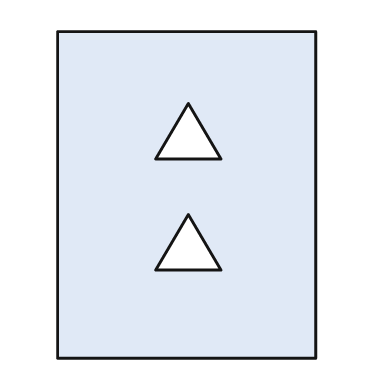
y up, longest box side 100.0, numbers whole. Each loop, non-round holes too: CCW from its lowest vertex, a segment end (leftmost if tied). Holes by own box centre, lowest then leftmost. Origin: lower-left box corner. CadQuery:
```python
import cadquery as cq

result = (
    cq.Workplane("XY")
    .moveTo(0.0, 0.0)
    .lineTo(79.0, 0.0)
    .lineTo(79.0, 100.0)
    .lineTo(0.0, 100.0)
    .close()
    .moveTo(30.0, 27.0)
    .lineTo(50.0, 27.0)
    .lineTo(40.0, 44.0)
    .close()
    .moveTo(30.0, 61.0)
    .lineTo(50.0, 61.0)
    .lineTo(40.0, 78.0)
    .close()
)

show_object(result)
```